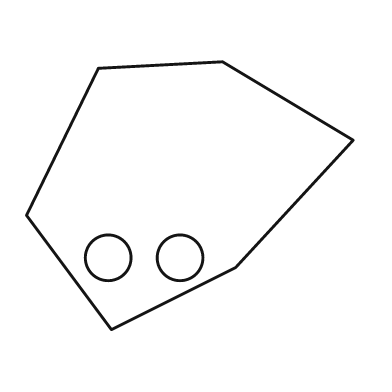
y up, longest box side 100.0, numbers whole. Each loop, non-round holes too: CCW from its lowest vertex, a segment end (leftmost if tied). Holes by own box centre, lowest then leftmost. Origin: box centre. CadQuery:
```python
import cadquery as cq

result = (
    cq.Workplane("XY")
    .moveTo(-24.0, -41.0)
    .lineTo(14.0, -22.0)
    .lineTo(50.0, 17.0)
    .lineTo(10.0, 41.0)
    .lineTo(-28.0, 39.0)
    .lineTo(-50.0, -6.0)
    .close()
    .moveTo(-25.0, -19.0)
    .circle(7.0)
    .moveTo(-3.0, -19.0)
    .circle(7.0)
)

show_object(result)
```